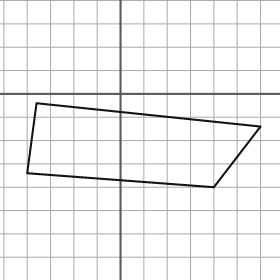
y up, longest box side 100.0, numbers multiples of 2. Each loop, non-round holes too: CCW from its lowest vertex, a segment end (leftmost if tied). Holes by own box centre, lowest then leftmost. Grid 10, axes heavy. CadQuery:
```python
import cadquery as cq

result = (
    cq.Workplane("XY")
    .moveTo(40.0, -40.0)
    .lineTo(60.0, -14.0)
    .lineTo(-36.0, -4.0)
    .lineTo(-40.0, -34.0)
    .close()
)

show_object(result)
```